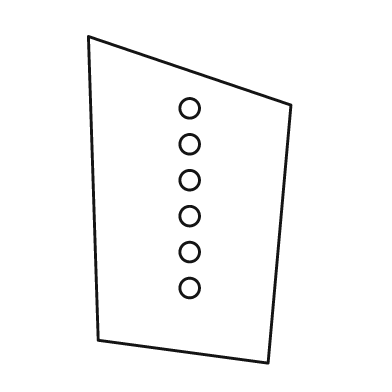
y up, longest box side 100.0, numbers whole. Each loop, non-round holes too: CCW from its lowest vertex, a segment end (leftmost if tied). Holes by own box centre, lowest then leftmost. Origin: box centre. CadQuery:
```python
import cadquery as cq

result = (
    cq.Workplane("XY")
    .moveTo(24.0, -50.0)
    .lineTo(31.0, 29.0)
    .lineTo(-31.0, 50.0)
    .lineTo(-28.0, -43.0)
    .close()
    .moveTo(0.0, -27.0)
    .circle(3.0)
    .moveTo(0.0, -16.0)
    .circle(3.0)
    .moveTo(0.0, -5.0)
    .circle(3.0)
    .moveTo(0.0, 6.0)
    .circle(3.0)
    .moveTo(0.0, 17.0)
    .circle(3.0)
    .moveTo(0.0, 28.0)
    .circle(3.0)
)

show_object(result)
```